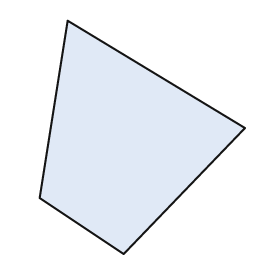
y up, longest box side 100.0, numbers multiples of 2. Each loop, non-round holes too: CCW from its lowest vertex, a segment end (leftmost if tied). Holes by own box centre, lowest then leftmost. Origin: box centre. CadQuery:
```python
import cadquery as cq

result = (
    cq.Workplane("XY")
    .moveTo(-8.0, -50.0)
    .lineTo(44.0, 4.0)
    .lineTo(-32.0, 50.0)
    .lineTo(-44.0, -26.0)
    .close()
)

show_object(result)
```